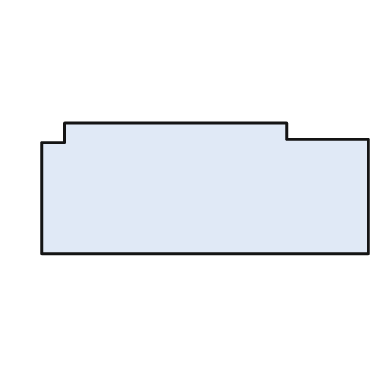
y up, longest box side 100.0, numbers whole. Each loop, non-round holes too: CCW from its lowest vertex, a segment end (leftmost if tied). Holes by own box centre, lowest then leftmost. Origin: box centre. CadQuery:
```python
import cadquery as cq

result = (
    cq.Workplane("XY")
    .moveTo(-50.0, -20.0)
    .lineTo(50.0, -20.0)
    .lineTo(50.0, 15.0)
    .lineTo(25.0, 15.0)
    .lineTo(25.0, 20.0)
    .lineTo(-43.0, 20.0)
    .lineTo(-43.0, 14.0)
    .lineTo(-50.0, 14.0)
    .close()
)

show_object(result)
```